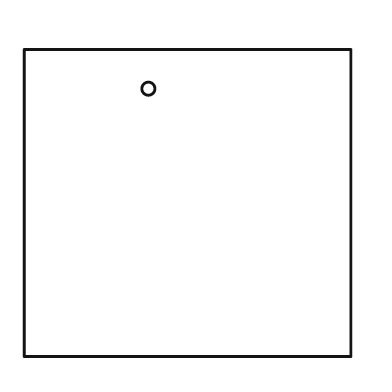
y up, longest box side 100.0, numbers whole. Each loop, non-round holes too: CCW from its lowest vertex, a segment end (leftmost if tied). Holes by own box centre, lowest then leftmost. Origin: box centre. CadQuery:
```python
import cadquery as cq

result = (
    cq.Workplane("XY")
    .moveTo(-50.0, -47.0)
    .lineTo(50.0, -47.0)
    .lineTo(50.0, 47.0)
    .lineTo(-50.0, 47.0)
    .close()
    .moveTo(-12.0, 35.0)
    .circle(2.0)
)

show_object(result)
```